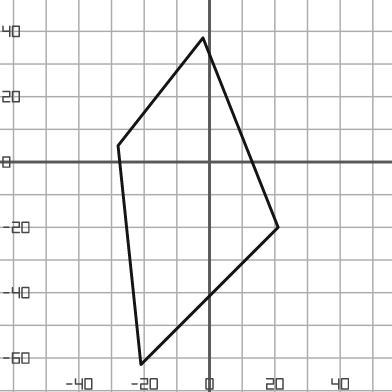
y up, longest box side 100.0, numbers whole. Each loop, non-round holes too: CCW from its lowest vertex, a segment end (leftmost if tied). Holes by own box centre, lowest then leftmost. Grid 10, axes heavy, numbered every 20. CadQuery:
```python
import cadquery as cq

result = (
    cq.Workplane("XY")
    .moveTo(-21.0, -62.0)
    .lineTo(21.0, -20.0)
    .lineTo(-2.0, 38.0)
    .lineTo(-28.0, 5.0)
    .close()
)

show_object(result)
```